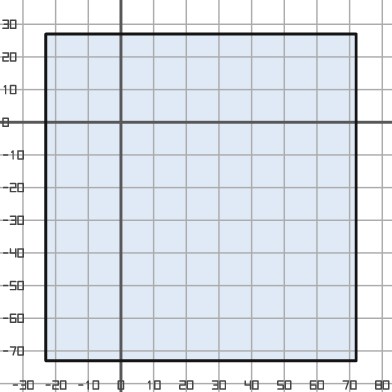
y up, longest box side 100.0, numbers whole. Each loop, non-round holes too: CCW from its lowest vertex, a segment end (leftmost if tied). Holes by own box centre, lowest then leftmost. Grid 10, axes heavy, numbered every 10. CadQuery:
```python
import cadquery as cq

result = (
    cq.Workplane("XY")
    .moveTo(-23.0, -73.0)
    .lineTo(72.0, -73.0)
    .lineTo(72.0, 27.0)
    .lineTo(-23.0, 27.0)
    .close()
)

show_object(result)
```